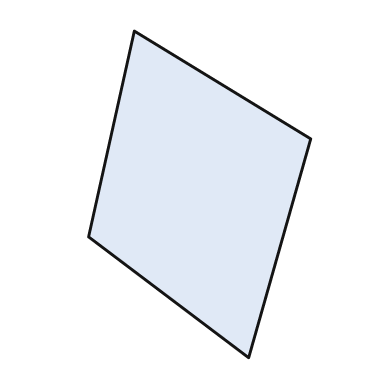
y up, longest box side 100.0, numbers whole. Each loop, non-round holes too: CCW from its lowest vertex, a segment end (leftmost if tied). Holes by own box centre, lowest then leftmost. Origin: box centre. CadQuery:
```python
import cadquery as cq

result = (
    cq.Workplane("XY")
    .moveTo(15.0, -50.0)
    .lineTo(34.0, 17.0)
    .lineTo(-20.0, 50.0)
    .lineTo(-34.0, -13.0)
    .close()
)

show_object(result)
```